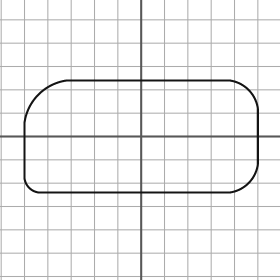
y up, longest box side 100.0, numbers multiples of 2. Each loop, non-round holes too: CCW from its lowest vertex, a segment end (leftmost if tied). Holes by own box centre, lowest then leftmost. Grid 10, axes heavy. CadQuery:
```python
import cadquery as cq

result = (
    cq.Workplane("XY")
    .moveTo(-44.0, -24.0)
    .lineTo(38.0, -24.0)
    .threePointArc((46.0, -20.0), (50.0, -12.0))
    .lineTo(50.0, 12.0)
    .threePointArc((46.0, 20.0), (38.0, 24.0))
    .lineTo(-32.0, 24.0)
    .threePointArc((-44.0, 18.0), (-50.0, 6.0))
    .lineTo(-50.0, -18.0)
    .threePointArc((-48.0, -22.0), (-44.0, -24.0))
    .close()
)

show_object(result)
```